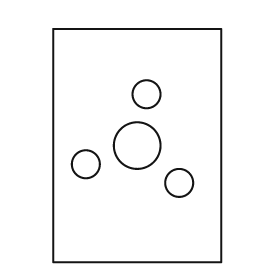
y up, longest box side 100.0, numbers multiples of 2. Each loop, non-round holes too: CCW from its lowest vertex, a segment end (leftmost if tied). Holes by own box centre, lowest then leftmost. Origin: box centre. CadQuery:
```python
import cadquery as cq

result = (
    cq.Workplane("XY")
    .moveTo(-36.0, -50.0)
    .lineTo(36.0, -50.0)
    .lineTo(36.0, 50.0)
    .lineTo(-36.0, 50.0)
    .close()
    .moveTo(18.0, -16.0)
    .circle(6.0)
    .moveTo(-22.0, -8.0)
    .circle(6.0)
    .moveTo(0.0, 0.0)
    .circle(10.0)
    .moveTo(4.0, 22.0)
    .circle(6.0)
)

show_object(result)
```